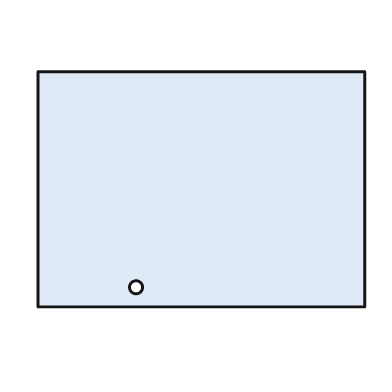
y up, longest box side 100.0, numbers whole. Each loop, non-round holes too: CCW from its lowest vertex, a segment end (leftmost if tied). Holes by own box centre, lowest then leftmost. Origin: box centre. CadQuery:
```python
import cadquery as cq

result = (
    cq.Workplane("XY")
    .moveTo(-50.0, -36.0)
    .lineTo(50.0, -36.0)
    .lineTo(50.0, 36.0)
    .lineTo(-50.0, 36.0)
    .close()
    .moveTo(-20.0, -30.0)
    .circle(2.0)
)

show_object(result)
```